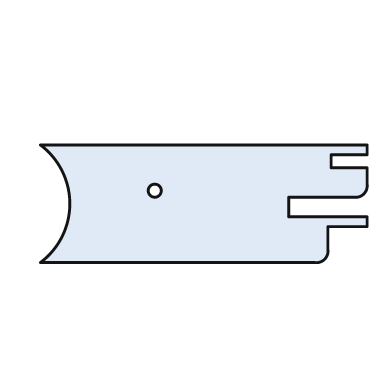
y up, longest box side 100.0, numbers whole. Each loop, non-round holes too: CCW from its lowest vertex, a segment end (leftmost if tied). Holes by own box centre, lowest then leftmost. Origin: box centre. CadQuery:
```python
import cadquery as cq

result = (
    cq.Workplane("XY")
    .moveTo(-50.0, -18.0)
    .lineTo(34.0, -18.0)
    .threePointArc((37.0, -17.0), (38.0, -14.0))
    .lineTo(38.0, -7.0)
    .lineTo(50.0, -7.0)
    .lineTo(50.0, -4.0)
    .lineTo(26.0, -4.0)
    .lineTo(26.0, 2.0)
    .lineTo(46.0, 2.0)
    .threePointArc((49.0, 3.0), (50.0, 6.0))
    .lineTo(50.0, 11.0)
    .lineTo(39.0, 11.0)
    .lineTo(39.0, 15.0)
    .lineTo(50.0, 15.0)
    .lineTo(50.0, 18.0)
    .lineTo(-50.0, 18.0)
    .threePointArc((-41.0, 0.0), (-50.0, -18.0))
    .close()
    .moveTo(-15.0, 4.0)
    .circle(2.0)
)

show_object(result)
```